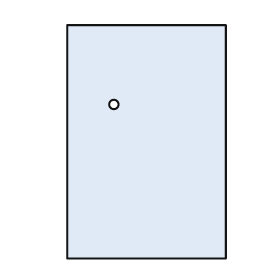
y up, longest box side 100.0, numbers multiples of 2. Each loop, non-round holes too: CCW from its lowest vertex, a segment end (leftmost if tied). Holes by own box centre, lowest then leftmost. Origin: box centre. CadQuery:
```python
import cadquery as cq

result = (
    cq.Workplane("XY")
    .moveTo(-34.0, -50.0)
    .lineTo(34.0, -50.0)
    .lineTo(34.0, 50.0)
    .lineTo(-34.0, 50.0)
    .close()
    .moveTo(-14.0, 16.0)
    .circle(2.0)
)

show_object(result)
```